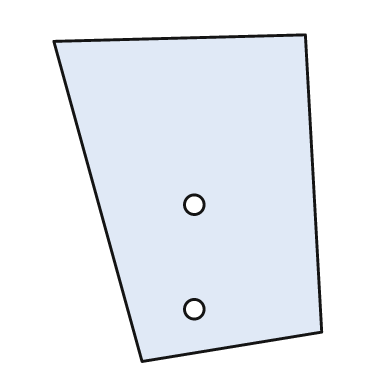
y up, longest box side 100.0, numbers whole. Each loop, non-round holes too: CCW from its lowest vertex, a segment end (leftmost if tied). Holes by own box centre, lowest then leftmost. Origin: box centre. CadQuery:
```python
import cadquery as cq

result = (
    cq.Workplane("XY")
    .moveTo(-14.0, -50.0)
    .lineTo(41.0, -41.0)
    .lineTo(36.0, 50.0)
    .lineTo(-41.0, 48.0)
    .close()
    .moveTo(2.0, -34.0)
    .circle(3.0)
    .moveTo(2.0, -2.0)
    .circle(3.0)
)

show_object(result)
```